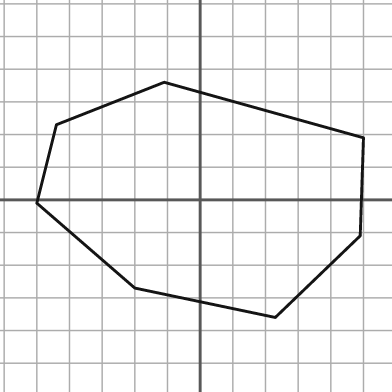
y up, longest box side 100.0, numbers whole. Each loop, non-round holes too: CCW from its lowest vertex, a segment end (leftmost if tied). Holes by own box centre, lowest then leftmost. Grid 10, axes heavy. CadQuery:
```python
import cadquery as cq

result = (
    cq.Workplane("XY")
    .moveTo(23.0, -36.0)
    .lineTo(49.0, -11.0)
    .lineTo(50.0, 19.0)
    .lineTo(-11.0, 36.0)
    .lineTo(-44.0, 23.0)
    .lineTo(-50.0, -1.0)
    .lineTo(-20.0, -27.0)
    .close()
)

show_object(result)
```